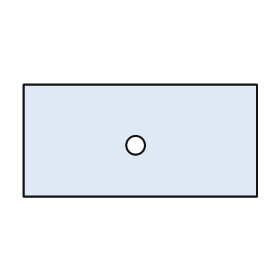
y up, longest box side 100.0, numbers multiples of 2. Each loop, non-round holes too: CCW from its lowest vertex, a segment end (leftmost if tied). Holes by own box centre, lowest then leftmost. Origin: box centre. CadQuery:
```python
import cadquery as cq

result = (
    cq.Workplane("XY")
    .moveTo(-50.0, -24.0)
    .lineTo(50.0, -24.0)
    .lineTo(50.0, 24.0)
    .lineTo(-50.0, 24.0)
    .close()
    .moveTo(-2.0, -2.0)
    .circle(4.0)
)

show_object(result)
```